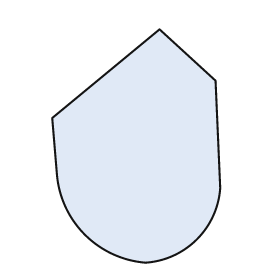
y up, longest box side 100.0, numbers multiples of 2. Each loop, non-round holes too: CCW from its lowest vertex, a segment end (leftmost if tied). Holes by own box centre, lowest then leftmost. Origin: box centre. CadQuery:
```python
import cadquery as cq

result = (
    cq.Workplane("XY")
    .moveTo(4.0, -50.0)
    .threePointArc((26.0, -40.0), (36.0, -18.0))
    .lineTo(34.0, 28.0)
    .lineTo(10.0, 50.0)
    .lineTo(-36.0, 12.0)
    .lineTo(-34.0, -12.0)
    .threePointArc((-22.0, -38.0), (4.0, -50.0))
    .close()
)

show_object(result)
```